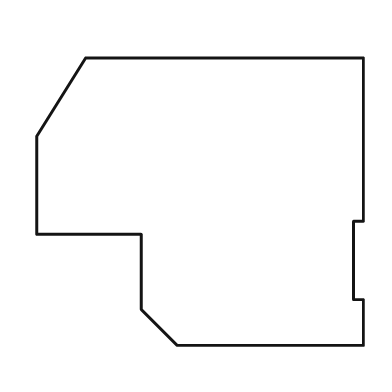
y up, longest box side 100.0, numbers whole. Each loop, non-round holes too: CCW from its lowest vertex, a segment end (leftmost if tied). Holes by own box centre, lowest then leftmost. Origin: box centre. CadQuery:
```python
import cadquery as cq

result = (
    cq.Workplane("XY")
    .moveTo(-7.0, -44.0)
    .lineTo(50.0, -44.0)
    .lineTo(50.0, -30.0)
    .lineTo(47.0, -30.0)
    .lineTo(47.0, -6.0)
    .lineTo(50.0, -6.0)
    .lineTo(50.0, 44.0)
    .lineTo(-35.0, 44.0)
    .lineTo(-50.0, 20.0)
    .lineTo(-50.0, -10.0)
    .lineTo(-18.0, -10.0)
    .lineTo(-18.0, -33.0)
    .close()
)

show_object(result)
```